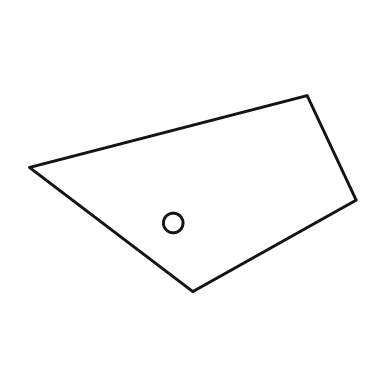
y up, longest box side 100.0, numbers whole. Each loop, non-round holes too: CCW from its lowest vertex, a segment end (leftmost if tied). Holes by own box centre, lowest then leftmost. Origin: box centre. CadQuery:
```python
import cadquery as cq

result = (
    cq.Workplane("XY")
    .moveTo(0.0, -30.0)
    .lineTo(50.0, -2.0)
    .lineTo(35.0, 30.0)
    .lineTo(-50.0, 8.0)
    .close()
    .moveTo(-6.0, -9.0)
    .circle(3.0)
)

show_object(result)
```